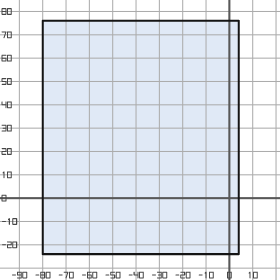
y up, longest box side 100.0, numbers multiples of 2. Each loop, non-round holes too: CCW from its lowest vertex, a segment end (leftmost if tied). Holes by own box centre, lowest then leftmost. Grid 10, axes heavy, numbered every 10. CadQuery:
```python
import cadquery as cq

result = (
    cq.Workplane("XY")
    .moveTo(-80.0, -24.0)
    .lineTo(4.0, -24.0)
    .lineTo(4.0, 76.0)
    .lineTo(-80.0, 76.0)
    .close()
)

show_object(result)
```